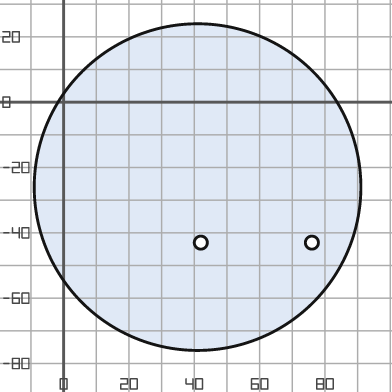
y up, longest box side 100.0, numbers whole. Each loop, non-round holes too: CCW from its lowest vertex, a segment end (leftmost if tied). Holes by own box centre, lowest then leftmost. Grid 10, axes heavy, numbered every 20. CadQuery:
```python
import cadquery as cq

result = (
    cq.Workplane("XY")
    .moveTo(41.0, -26.0)
    .circle(50.0)
    .moveTo(42.0, -43.0)
    .circle(2.0)
    .moveTo(76.0, -43.0)
    .circle(2.0)
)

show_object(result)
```